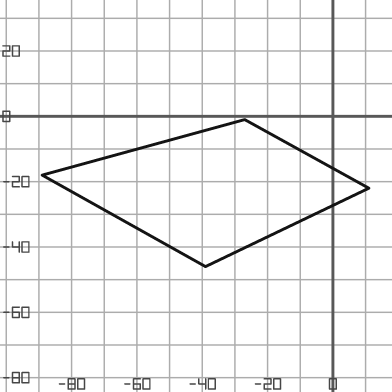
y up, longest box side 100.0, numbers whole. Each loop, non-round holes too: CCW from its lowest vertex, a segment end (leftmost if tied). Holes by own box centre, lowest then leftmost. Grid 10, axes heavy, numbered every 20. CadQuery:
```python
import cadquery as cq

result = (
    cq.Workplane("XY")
    .moveTo(-39.0, -46.0)
    .lineTo(11.0, -22.0)
    .lineTo(-27.0, -1.0)
    .lineTo(-89.0, -18.0)
    .close()
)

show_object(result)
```